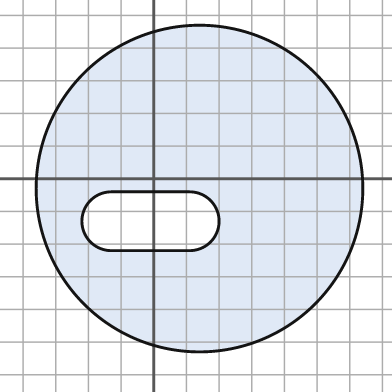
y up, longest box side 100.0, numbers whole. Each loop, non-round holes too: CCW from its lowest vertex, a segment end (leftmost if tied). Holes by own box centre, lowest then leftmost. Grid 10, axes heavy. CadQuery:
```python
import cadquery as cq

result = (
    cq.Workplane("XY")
    .moveTo(14.0, -3.0)
    .circle(50.0)
    .moveTo(-13.0, -22.0)
    .lineTo(11.0, -22.0)
    .threePointArc((20.0, -13.0), (11.0, -4.0))
    .lineTo(-13.0, -4.0)
    .threePointArc((-22.0, -13.0), (-13.0, -22.0))
    .close()
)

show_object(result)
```